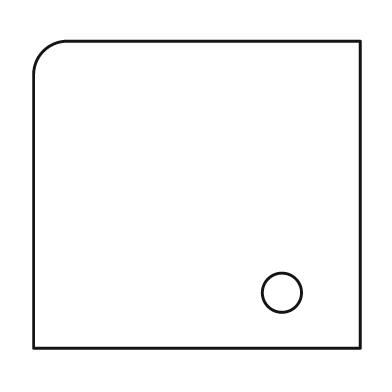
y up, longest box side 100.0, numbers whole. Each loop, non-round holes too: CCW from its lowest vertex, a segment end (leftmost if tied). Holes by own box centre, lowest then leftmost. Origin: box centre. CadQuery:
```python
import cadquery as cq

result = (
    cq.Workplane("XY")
    .moveTo(-50.0, -47.0)
    .lineTo(50.0, -47.0)
    .lineTo(50.0, 47.0)
    .lineTo(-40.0, 47.0)
    .threePointArc((-47.0, 44.0), (-50.0, 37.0))
    .close()
    .moveTo(26.0, -30.0)
    .circle(6.0)
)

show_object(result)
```